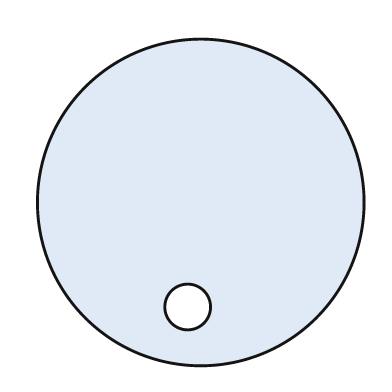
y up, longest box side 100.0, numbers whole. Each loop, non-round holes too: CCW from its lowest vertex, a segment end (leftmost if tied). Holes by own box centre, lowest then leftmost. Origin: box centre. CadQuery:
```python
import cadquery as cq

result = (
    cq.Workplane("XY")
    .moveTo(0.0, 0.0)
    .circle(50.0)
    .moveTo(-4.0, -32.0)
    .circle(7.0)
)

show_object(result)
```